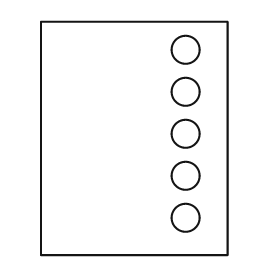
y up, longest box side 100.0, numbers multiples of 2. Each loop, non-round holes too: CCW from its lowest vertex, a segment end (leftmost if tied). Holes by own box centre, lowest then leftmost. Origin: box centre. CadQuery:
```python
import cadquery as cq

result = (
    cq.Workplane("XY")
    .moveTo(-40.0, -50.0)
    .lineTo(40.0, -50.0)
    .lineTo(40.0, 50.0)
    .lineTo(-40.0, 50.0)
    .close()
    .moveTo(22.0, -34.0)
    .circle(6.0)
    .moveTo(22.0, -16.0)
    .circle(6.0)
    .moveTo(22.0, 2.0)
    .circle(6.0)
    .moveTo(22.0, 20.0)
    .circle(6.0)
    .moveTo(22.0, 38.0)
    .circle(6.0)
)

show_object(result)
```